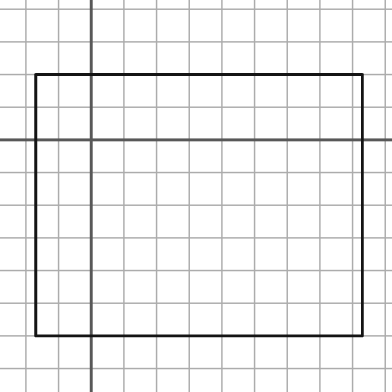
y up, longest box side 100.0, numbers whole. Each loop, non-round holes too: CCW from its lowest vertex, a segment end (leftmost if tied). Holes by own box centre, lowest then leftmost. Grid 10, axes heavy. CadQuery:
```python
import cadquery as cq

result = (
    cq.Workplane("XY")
    .moveTo(-17.0, -60.0)
    .lineTo(83.0, -60.0)
    .lineTo(83.0, 20.0)
    .lineTo(-17.0, 20.0)
    .close()
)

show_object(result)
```